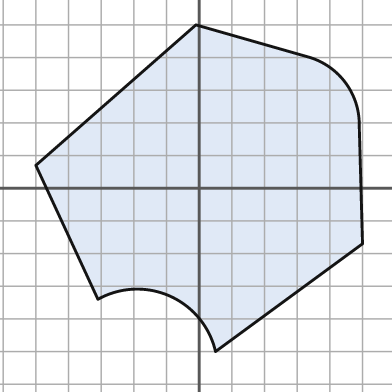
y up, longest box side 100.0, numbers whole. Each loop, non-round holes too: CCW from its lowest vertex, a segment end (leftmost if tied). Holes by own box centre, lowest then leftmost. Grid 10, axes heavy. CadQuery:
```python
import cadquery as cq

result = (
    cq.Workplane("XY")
    .moveTo(5.0, -50.0)
    .lineTo(50.0, -17.0)
    .lineTo(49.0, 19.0)
    .threePointArc((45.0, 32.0), (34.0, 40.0))
    .lineTo(-1.0, 50.0)
    .lineTo(-50.0, 7.0)
    .lineTo(-31.0, -34.0)
    .threePointArc((-9.0, -33.0), (5.0, -50.0))
    .close()
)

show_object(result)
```